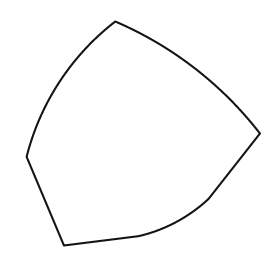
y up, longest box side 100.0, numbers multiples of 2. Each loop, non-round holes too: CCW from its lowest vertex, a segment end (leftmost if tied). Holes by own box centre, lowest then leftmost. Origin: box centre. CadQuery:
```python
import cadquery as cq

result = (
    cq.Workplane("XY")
    .moveTo(-34.0, -48.0)
    .lineTo(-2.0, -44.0)
    .threePointArc((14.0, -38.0), (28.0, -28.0))
    .lineTo(50.0, 0.0)
    .threePointArc((22.0, 28.0), (-12.0, 48.0))
    .threePointArc((-36.0, 22.0), (-50.0, -10.0))
    .close()
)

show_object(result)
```